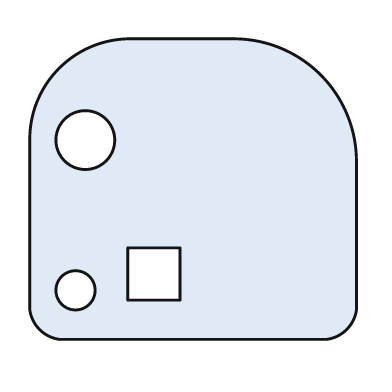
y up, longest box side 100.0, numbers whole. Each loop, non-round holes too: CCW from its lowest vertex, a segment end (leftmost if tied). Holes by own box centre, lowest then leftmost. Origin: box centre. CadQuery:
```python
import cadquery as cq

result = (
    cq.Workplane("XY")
    .moveTo(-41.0, -46.0)
    .lineTo(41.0, -46.0)
    .threePointArc((47.0, -43.0), (50.0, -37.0))
    .lineTo(50.0, 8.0)
    .threePointArc((39.0, 35.0), (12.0, 46.0))
    .lineTo(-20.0, 46.0)
    .threePointArc((-41.0, 37.0), (-50.0, 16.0))
    .lineTo(-50.0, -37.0)
    .threePointArc((-47.0, -43.0), (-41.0, -46.0))
    .close()
    .moveTo(-36.0, -31.0)
    .circle(6.0)
    .moveTo(-20.0, -34.0)
    .lineTo(-4.0, -34.0)
    .lineTo(-4.0, -18.0)
    .lineTo(-20.0, -18.0)
    .close()
    .moveTo(-33.0, 15.0)
    .circle(9.0)
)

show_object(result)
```